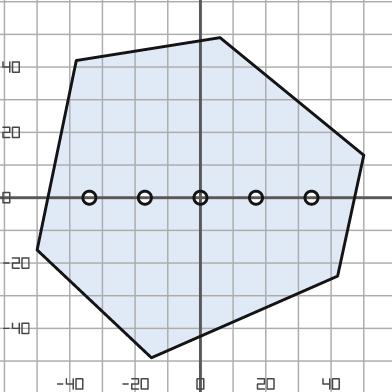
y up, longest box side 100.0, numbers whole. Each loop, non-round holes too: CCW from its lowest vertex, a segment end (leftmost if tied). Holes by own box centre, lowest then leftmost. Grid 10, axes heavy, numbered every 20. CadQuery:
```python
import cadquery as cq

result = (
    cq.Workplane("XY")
    .moveTo(-15.0, -49.0)
    .lineTo(42.0, -24.0)
    .lineTo(50.0, 13.0)
    .lineTo(6.0, 49.0)
    .lineTo(-38.0, 42.0)
    .lineTo(-50.0, -16.0)
    .close()
    .moveTo(-34.0, 0.0)
    .circle(2.0)
    .moveTo(-17.0, 0.0)
    .circle(2.0)
    .moveTo(0.0, 0.0)
    .circle(2.0)
    .moveTo(17.0, 0.0)
    .circle(2.0)
    .moveTo(34.0, 0.0)
    .circle(2.0)
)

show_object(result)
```